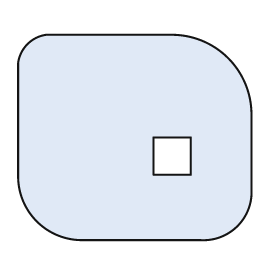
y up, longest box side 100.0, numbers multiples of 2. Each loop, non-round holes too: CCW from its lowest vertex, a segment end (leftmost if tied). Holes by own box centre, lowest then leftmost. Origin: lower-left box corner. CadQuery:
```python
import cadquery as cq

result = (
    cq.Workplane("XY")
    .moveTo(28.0, 0.0)
    .lineTo(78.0, 0.0)
    .threePointArc((94.0, 6.0), (100.0, 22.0))
    .lineTo(100.0, 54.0)
    .threePointArc((90.0, 78.0), (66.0, 88.0))
    .lineTo(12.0, 88.0)
    .threePointArc((4.0, 84.0), (0.0, 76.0))
    .lineTo(0.0, 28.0)
    .threePointArc((8.0, 8.0), (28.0, 0.0))
    .close()
    .moveTo(58.0, 28.0)
    .lineTo(74.0, 28.0)
    .lineTo(74.0, 44.0)
    .lineTo(58.0, 44.0)
    .close()
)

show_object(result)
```